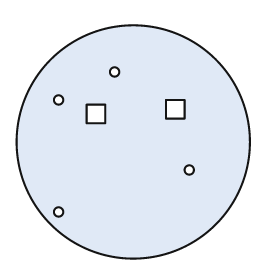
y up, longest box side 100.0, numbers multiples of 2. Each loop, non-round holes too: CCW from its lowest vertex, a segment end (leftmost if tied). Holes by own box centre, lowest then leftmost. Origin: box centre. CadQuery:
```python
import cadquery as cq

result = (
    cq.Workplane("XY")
    .moveTo(0.0, 0.0)
    .circle(50.0)
    .moveTo(-32.0, -30.0)
    .circle(2.0)
    .moveTo(24.0, -12.0)
    .circle(2.0)
    .moveTo(-20.0, 8.0)
    .lineTo(-12.0, 8.0)
    .lineTo(-12.0, 16.0)
    .lineTo(-20.0, 16.0)
    .close()
    .moveTo(14.0, 10.0)
    .lineTo(22.0, 10.0)
    .lineTo(22.0, 18.0)
    .lineTo(14.0, 18.0)
    .close()
    .moveTo(-32.0, 18.0)
    .circle(2.0)
    .moveTo(-8.0, 30.0)
    .circle(2.0)
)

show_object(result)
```